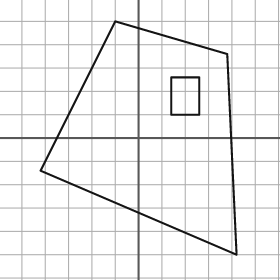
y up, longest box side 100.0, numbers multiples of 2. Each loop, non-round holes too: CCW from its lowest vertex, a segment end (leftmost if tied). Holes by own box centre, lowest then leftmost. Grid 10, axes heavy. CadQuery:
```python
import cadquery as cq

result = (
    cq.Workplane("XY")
    .moveTo(42.0, -50.0)
    .lineTo(38.0, 36.0)
    .lineTo(-10.0, 50.0)
    .lineTo(-42.0, -14.0)
    .close()
    .moveTo(14.0, 10.0)
    .lineTo(26.0, 10.0)
    .lineTo(26.0, 26.0)
    .lineTo(14.0, 26.0)
    .close()
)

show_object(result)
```